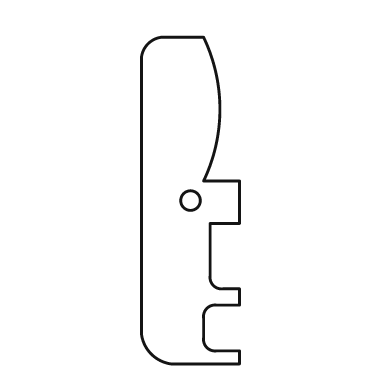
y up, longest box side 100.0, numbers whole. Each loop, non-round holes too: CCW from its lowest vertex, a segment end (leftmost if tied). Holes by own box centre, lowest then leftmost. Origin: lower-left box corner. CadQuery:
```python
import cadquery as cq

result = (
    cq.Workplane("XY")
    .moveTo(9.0, 0.0)
    .lineTo(30.0, 0.0)
    .lineTo(30.0, 4.0)
    .lineTo(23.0, 4.0)
    .threePointArc((20.0, 5.0), (19.0, 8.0))
    .lineTo(19.0, 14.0)
    .threePointArc((20.0, 17.0), (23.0, 18.0))
    .lineTo(30.0, 18.0)
    .lineTo(30.0, 23.0)
    .lineTo(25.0, 23.0)
    .threePointArc((22.0, 24.0), (21.0, 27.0))
    .lineTo(21.0, 43.0)
    .lineTo(30.0, 43.0)
    .lineTo(30.0, 56.0)
    .lineTo(19.0, 56.0)
    .threePointArc((24.0, 78.0), (19.0, 100.0))
    .lineTo(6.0, 100.0)
    .threePointArc((2.0, 98.0), (0.0, 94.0))
    .lineTo(0.0, 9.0)
    .threePointArc((3.0, 3.0), (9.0, 0.0))
    .close()
    .moveTo(15.0, 50.0)
    .circle(3.0)
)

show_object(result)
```